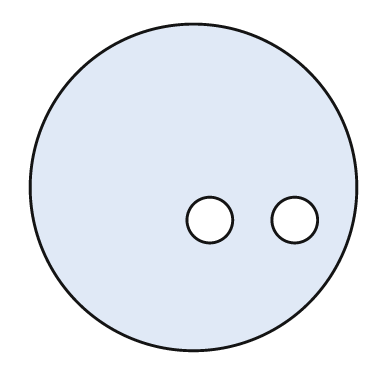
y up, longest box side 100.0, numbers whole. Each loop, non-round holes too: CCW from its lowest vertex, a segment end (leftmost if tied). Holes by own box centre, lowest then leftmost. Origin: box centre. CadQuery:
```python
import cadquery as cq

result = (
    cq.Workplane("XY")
    .moveTo(0.0, 0.0)
    .circle(50.0)
    .moveTo(5.0, -10.0)
    .circle(7.0)
    .moveTo(31.0, -10.0)
    .circle(7.0)
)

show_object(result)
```